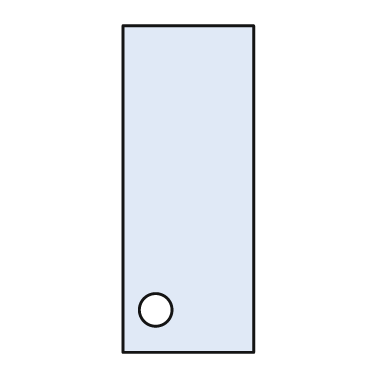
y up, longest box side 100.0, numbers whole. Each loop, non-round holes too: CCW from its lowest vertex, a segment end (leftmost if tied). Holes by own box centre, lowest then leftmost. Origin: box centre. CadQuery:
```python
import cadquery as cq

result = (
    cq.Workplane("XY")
    .moveTo(-20.0, -50.0)
    .lineTo(20.0, -50.0)
    .lineTo(20.0, 50.0)
    .lineTo(-20.0, 50.0)
    .close()
    .moveTo(-10.0, -37.0)
    .circle(5.0)
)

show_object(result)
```